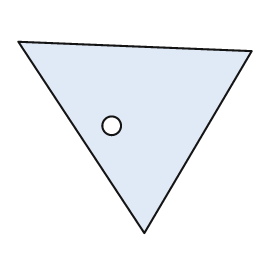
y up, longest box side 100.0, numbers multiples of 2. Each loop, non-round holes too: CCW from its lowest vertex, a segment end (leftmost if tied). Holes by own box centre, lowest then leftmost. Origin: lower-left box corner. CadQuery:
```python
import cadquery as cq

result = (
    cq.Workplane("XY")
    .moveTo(54.0, 0.0)
    .lineTo(100.0, 78.0)
    .lineTo(0.0, 82.0)
    .close()
    .moveTo(40.0, 46.0)
    .circle(4.0)
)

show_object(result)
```